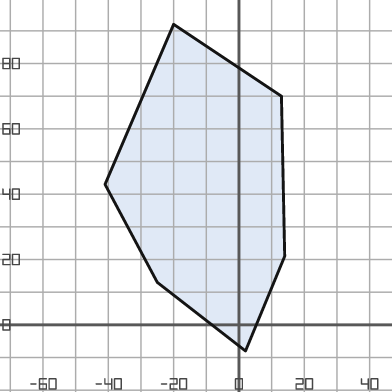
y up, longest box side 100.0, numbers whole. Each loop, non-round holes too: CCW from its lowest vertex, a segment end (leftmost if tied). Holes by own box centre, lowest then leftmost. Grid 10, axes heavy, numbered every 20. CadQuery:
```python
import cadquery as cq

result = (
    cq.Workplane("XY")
    .moveTo(2.0, -8.0)
    .lineTo(14.0, 21.0)
    .lineTo(13.0, 70.0)
    .lineTo(-20.0, 92.0)
    .lineTo(-41.0, 43.0)
    .lineTo(-25.0, 13.0)
    .close()
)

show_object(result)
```